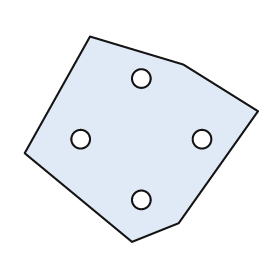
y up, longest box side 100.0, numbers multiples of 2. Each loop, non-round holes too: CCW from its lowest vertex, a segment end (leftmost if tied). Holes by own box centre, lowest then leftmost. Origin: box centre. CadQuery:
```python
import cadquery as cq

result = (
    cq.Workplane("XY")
    .moveTo(-4.0, -44.0)
    .lineTo(16.0, -36.0)
    .lineTo(50.0, 12.0)
    .lineTo(18.0, 32.0)
    .lineTo(-22.0, 44.0)
    .lineTo(-50.0, -6.0)
    .close()
    .moveTo(0.0, -26.0)
    .circle(4.0)
    .moveTo(-26.0, 0.0)
    .circle(4.0)
    .moveTo(26.0, 0.0)
    .circle(4.0)
    .moveTo(0.0, 26.0)
    .circle(4.0)
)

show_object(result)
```